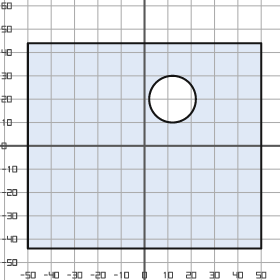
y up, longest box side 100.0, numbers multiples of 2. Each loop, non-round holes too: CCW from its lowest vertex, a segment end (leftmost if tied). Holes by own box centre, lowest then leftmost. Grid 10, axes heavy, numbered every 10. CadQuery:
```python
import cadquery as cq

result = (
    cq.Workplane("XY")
    .moveTo(-50.0, -44.0)
    .lineTo(50.0, -44.0)
    .lineTo(50.0, 44.0)
    .lineTo(-50.0, 44.0)
    .close()
    .moveTo(12.0, 20.0)
    .circle(10.0)
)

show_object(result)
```